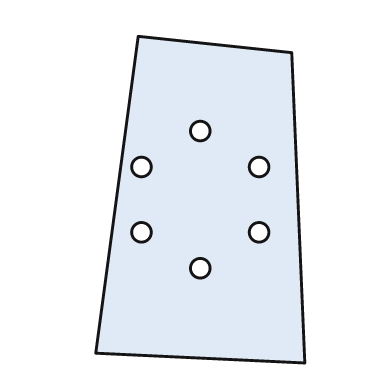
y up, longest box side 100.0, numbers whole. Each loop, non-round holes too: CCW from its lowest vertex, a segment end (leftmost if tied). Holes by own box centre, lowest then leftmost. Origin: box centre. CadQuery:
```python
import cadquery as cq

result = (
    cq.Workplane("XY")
    .moveTo(32.0, -50.0)
    .lineTo(28.0, 45.0)
    .lineTo(-19.0, 50.0)
    .lineTo(-32.0, -47.0)
    .close()
    .moveTo(0.0, -21.0)
    .circle(3.0)
    .moveTo(-18.0, -10.0)
    .circle(3.0)
    .moveTo(18.0, -10.0)
    .circle(3.0)
    .moveTo(-18.0, 10.0)
    .circle(3.0)
    .moveTo(18.0, 10.0)
    .circle(3.0)
    .moveTo(0.0, 21.0)
    .circle(3.0)
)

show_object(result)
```